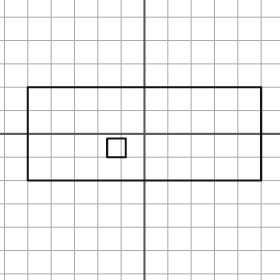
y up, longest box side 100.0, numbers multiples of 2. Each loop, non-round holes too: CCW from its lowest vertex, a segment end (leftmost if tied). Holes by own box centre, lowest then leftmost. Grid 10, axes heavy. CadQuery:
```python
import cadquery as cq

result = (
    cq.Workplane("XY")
    .moveTo(-50.0, -20.0)
    .lineTo(50.0, -20.0)
    .lineTo(50.0, 20.0)
    .lineTo(-50.0, 20.0)
    .close()
    .moveTo(-16.0, -10.0)
    .lineTo(-8.0, -10.0)
    .lineTo(-8.0, -2.0)
    .lineTo(-16.0, -2.0)
    .close()
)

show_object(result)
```